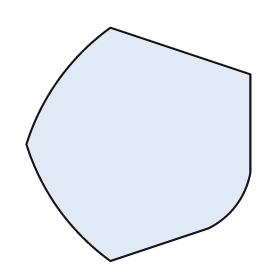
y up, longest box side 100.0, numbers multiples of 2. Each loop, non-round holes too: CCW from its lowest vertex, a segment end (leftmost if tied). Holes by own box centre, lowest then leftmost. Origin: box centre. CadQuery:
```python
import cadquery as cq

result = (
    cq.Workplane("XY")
    .moveTo(-12.0, -50.0)
    .lineTo(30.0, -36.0)
    .threePointArc((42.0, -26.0), (48.0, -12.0))
    .lineTo(48.0, 30.0)
    .lineTo(-12.0, 50.0)
    .threePointArc((-34.0, 28.0), (-48.0, 0.0))
    .threePointArc((-34.0, -28.0), (-12.0, -50.0))
    .close()
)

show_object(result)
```